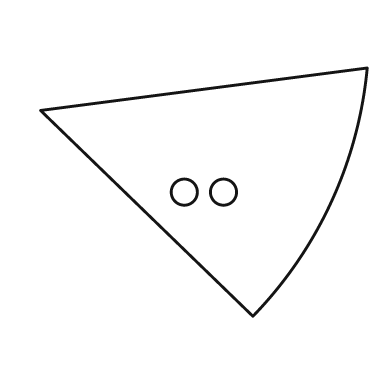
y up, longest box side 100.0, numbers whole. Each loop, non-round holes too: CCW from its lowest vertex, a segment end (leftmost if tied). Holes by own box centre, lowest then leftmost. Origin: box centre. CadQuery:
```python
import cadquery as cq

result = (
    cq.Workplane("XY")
    .moveTo(15.0, -38.0)
    .threePointArc((39.0, -3.0), (50.0, 38.0))
    .lineTo(-50.0, 25.0)
    .close()
    .moveTo(-6.0, 0.0)
    .circle(4.0)
    .moveTo(6.0, 0.0)
    .circle(4.0)
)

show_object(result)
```